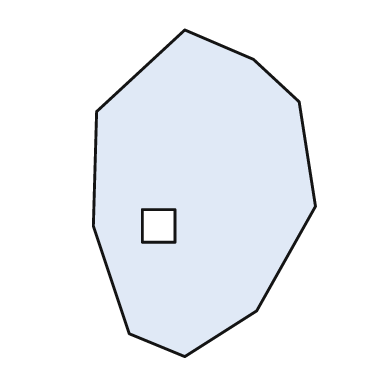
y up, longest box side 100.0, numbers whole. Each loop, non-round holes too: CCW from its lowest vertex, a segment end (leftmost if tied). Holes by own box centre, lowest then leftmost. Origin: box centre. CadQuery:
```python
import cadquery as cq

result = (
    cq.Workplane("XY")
    .moveTo(-6.0, -50.0)
    .lineTo(16.0, -36.0)
    .lineTo(34.0, -4.0)
    .lineTo(29.0, 28.0)
    .lineTo(15.0, 41.0)
    .lineTo(-6.0, 50.0)
    .lineTo(-33.0, 25.0)
    .lineTo(-34.0, -10.0)
    .lineTo(-23.0, -43.0)
    .close()
    .moveTo(-19.0, -15.0)
    .lineTo(-9.0, -15.0)
    .lineTo(-9.0, -5.0)
    .lineTo(-19.0, -5.0)
    .close()
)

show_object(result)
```